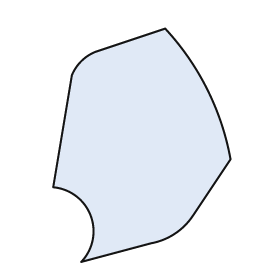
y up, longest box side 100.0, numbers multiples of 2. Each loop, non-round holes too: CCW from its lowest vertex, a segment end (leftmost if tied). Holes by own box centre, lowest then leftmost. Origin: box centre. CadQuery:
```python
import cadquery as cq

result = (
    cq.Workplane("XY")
    .moveTo(-26.0, -50.0)
    .lineTo(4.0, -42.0)
    .threePointArc((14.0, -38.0), (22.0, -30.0))
    .lineTo(38.0, -6.0)
    .threePointArc((28.0, 24.0), (10.0, 50.0))
    .lineTo(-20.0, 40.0)
    .threePointArc((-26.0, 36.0), (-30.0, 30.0))
    .lineTo(-38.0, -18.0)
    .threePointArc((-22.0, -30.0), (-26.0, -50.0))
    .close()
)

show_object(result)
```